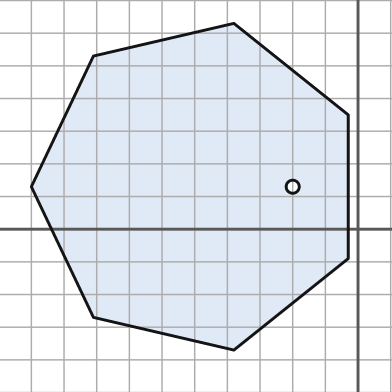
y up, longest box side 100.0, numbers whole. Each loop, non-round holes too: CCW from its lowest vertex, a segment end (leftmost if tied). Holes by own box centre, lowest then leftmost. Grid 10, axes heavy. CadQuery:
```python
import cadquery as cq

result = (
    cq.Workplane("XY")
    .moveTo(-38.0, -37.0)
    .lineTo(-3.0, -9.0)
    .lineTo(-3.0, 35.0)
    .lineTo(-38.0, 63.0)
    .lineTo(-81.0, 53.0)
    .lineTo(-100.0, 13.0)
    .lineTo(-81.0, -27.0)
    .close()
    .moveTo(-20.0, 13.0)
    .circle(2.0)
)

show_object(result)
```